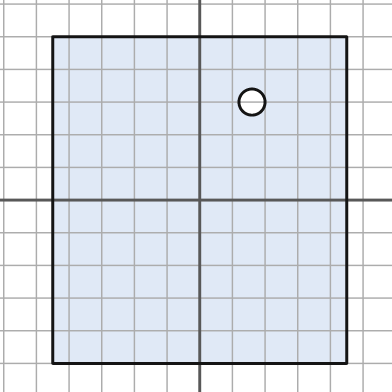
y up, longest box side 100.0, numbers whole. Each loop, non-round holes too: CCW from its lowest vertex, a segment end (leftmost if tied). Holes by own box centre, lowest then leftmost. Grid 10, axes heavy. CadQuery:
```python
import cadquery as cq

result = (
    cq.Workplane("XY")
    .moveTo(-45.0, -50.0)
    .lineTo(45.0, -50.0)
    .lineTo(45.0, 50.0)
    .lineTo(-45.0, 50.0)
    .close()
    .moveTo(16.0, 30.0)
    .circle(4.0)
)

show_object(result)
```